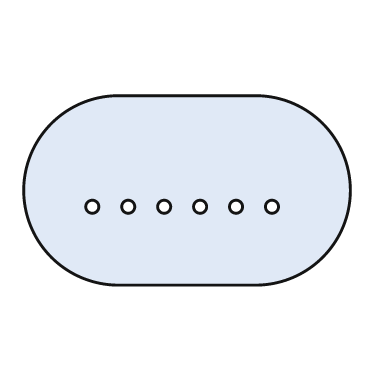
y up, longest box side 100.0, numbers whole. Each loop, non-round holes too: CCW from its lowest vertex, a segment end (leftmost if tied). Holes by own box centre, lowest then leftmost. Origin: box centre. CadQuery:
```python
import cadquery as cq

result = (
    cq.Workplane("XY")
    .moveTo(-21.0, -29.0)
    .lineTo(21.0, -29.0)
    .threePointArc((50.0, 0.0), (21.0, 29.0))
    .lineTo(-21.0, 29.0)
    .threePointArc((-50.0, 0.0), (-21.0, -29.0))
    .close()
    .moveTo(-29.0, -5.0)
    .circle(2.0)
    .moveTo(-18.0, -5.0)
    .circle(2.0)
    .moveTo(-7.0, -5.0)
    .circle(2.0)
    .moveTo(4.0, -5.0)
    .circle(2.0)
    .moveTo(15.0, -5.0)
    .circle(2.0)
    .moveTo(26.0, -5.0)
    .circle(2.0)
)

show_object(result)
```